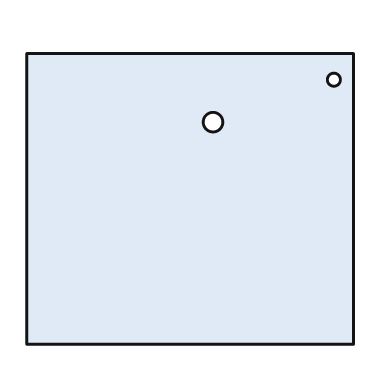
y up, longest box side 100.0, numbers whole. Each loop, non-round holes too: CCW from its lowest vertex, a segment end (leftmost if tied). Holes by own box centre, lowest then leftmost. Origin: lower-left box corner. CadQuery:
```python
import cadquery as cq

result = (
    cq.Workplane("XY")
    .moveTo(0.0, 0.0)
    .lineTo(100.0, 0.0)
    .lineTo(100.0, 89.0)
    .lineTo(0.0, 89.0)
    .close()
    .moveTo(57.0, 68.0)
    .circle(3.0)
    .moveTo(94.0, 81.0)
    .circle(2.0)
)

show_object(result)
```